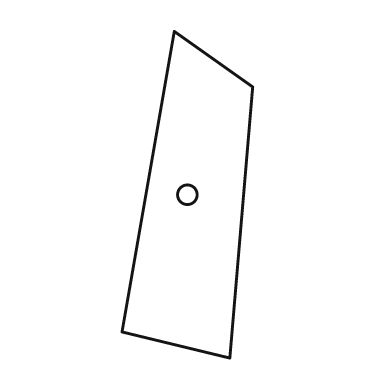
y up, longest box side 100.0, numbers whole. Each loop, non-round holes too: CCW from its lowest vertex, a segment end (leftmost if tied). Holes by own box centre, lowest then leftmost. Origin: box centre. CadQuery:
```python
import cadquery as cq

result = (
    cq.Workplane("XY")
    .moveTo(13.0, -50.0)
    .lineTo(20.0, 33.0)
    .lineTo(-4.0, 50.0)
    .lineTo(-20.0, -42.0)
    .close()
    .moveTo(0.0, 0.0)
    .circle(3.0)
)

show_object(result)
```